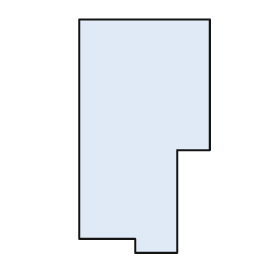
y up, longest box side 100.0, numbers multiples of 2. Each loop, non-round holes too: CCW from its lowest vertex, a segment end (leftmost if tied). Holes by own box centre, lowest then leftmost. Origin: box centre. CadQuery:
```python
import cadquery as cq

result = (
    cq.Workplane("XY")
    .moveTo(-4.0, -50.0)
    .lineTo(14.0, -50.0)
    .lineTo(14.0, -6.0)
    .lineTo(28.0, -6.0)
    .lineTo(28.0, 50.0)
    .lineTo(-28.0, 50.0)
    .lineTo(-28.0, -44.0)
    .lineTo(-4.0, -44.0)
    .close()
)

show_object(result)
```